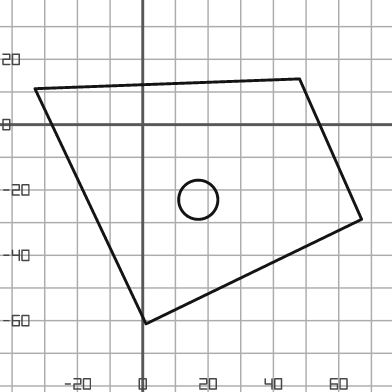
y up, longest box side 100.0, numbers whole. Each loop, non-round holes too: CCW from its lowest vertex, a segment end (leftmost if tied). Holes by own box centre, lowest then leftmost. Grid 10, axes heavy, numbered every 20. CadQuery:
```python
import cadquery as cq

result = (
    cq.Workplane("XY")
    .moveTo(1.0, -61.0)
    .lineTo(67.0, -29.0)
    .lineTo(48.0, 14.0)
    .lineTo(-33.0, 11.0)
    .close()
    .moveTo(17.0, -23.0)
    .circle(6.0)
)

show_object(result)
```